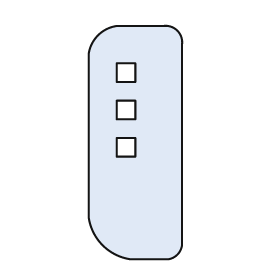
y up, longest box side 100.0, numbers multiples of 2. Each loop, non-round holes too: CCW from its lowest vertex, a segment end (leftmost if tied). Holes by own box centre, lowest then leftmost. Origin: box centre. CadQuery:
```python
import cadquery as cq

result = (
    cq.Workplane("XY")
    .moveTo(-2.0, -50.0)
    .lineTo(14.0, -50.0)
    .threePointArc((18.0, -48.0), (20.0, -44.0))
    .lineTo(20.0, 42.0)
    .threePointArc((18.0, 48.0), (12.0, 50.0))
    .lineTo(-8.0, 50.0)
    .threePointArc((-16.0, 46.0), (-20.0, 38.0))
    .lineTo(-20.0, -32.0)
    .threePointArc((-14.0, -44.0), (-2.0, -50.0))
    .close()
    .moveTo(-8.0, -6.0)
    .lineTo(0.0, -6.0)
    .lineTo(0.0, 2.0)
    .lineTo(-8.0, 2.0)
    .close()
    .moveTo(-8.0, 10.0)
    .lineTo(0.0, 10.0)
    .lineTo(0.0, 18.0)
    .lineTo(-8.0, 18.0)
    .close()
    .moveTo(-8.0, 26.0)
    .lineTo(0.0, 26.0)
    .lineTo(0.0, 34.0)
    .lineTo(-8.0, 34.0)
    .close()
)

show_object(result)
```